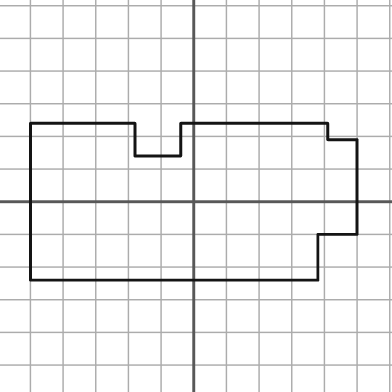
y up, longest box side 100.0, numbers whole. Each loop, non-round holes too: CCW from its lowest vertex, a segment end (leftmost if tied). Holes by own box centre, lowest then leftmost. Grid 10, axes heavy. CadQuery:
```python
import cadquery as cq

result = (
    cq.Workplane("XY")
    .moveTo(-50.0, -24.0)
    .lineTo(38.0, -24.0)
    .lineTo(38.0, -10.0)
    .lineTo(50.0, -10.0)
    .lineTo(50.0, 19.0)
    .lineTo(41.0, 19.0)
    .lineTo(41.0, 24.0)
    .lineTo(-4.0, 24.0)
    .lineTo(-4.0, 14.0)
    .lineTo(-18.0, 14.0)
    .lineTo(-18.0, 24.0)
    .lineTo(-50.0, 24.0)
    .close()
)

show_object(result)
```